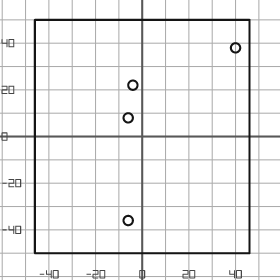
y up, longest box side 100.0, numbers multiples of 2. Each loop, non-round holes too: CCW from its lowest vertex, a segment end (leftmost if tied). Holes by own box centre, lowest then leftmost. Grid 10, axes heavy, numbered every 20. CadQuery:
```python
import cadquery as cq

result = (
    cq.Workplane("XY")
    .moveTo(-46.0, -50.0)
    .lineTo(46.0, -50.0)
    .lineTo(46.0, 50.0)
    .lineTo(-46.0, 50.0)
    .close()
    .moveTo(-6.0, -36.0)
    .circle(2.0)
    .moveTo(-6.0, 8.0)
    .circle(2.0)
    .moveTo(-4.0, 22.0)
    .circle(2.0)
    .moveTo(40.0, 38.0)
    .circle(2.0)
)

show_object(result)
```